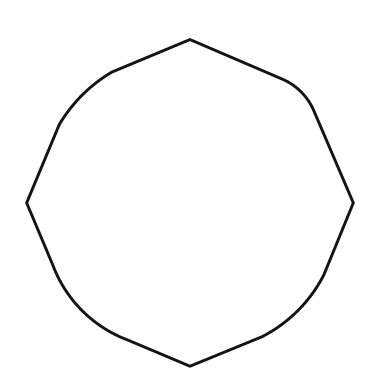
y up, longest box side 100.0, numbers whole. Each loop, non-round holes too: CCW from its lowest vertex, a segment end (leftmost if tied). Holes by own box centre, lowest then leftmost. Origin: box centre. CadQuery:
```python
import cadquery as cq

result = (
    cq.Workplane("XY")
    .moveTo(0.0, -50.0)
    .lineTo(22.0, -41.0)
    .threePointArc((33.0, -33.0), (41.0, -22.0))
    .lineTo(50.0, 0.0)
    .lineTo(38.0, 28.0)
    .threePointArc((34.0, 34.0), (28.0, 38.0))
    .lineTo(0.0, 50.0)
    .lineTo(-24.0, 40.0)
    .threePointArc((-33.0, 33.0), (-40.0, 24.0))
    .lineTo(-50.0, 0.0)
    .lineTo(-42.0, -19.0)
    .threePointArc((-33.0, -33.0), (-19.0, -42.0))
    .close()
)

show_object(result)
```